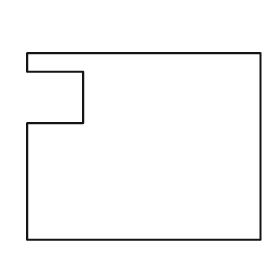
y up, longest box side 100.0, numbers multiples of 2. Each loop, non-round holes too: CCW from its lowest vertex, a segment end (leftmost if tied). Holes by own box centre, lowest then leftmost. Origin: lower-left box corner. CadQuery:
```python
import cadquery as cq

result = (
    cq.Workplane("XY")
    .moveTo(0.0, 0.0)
    .lineTo(100.0, 0.0)
    .lineTo(100.0, 80.0)
    .lineTo(0.0, 80.0)
    .lineTo(0.0, 72.0)
    .lineTo(24.0, 72.0)
    .lineTo(24.0, 50.0)
    .lineTo(0.0, 50.0)
    .close()
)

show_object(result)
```